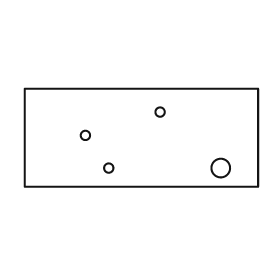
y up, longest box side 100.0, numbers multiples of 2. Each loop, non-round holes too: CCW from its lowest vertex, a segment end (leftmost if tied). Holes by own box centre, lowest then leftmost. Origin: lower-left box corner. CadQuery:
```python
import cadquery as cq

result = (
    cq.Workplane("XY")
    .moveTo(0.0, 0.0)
    .lineTo(100.0, 0.0)
    .lineTo(100.0, 42.0)
    .lineTo(0.0, 42.0)
    .close()
    .moveTo(36.0, 8.0)
    .circle(2.0)
    .moveTo(84.0, 8.0)
    .circle(4.0)
    .moveTo(26.0, 22.0)
    .circle(2.0)
    .moveTo(58.0, 32.0)
    .circle(2.0)
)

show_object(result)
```